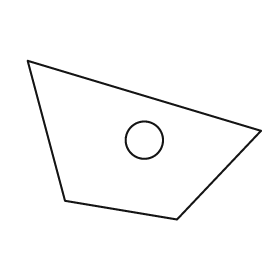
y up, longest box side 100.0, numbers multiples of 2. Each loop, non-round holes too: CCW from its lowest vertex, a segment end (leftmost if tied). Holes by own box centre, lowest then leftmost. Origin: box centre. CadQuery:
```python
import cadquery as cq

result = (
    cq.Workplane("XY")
    .moveTo(14.0, -34.0)
    .lineTo(50.0, 4.0)
    .lineTo(-50.0, 34.0)
    .lineTo(-34.0, -26.0)
    .close()
    .moveTo(0.0, 0.0)
    .circle(8.0)
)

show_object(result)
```